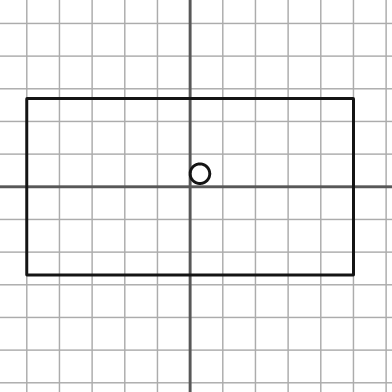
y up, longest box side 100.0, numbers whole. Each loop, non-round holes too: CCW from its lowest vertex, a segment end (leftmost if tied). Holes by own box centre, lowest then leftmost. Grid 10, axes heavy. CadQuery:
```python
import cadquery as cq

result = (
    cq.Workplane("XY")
    .moveTo(-50.0, -27.0)
    .lineTo(50.0, -27.0)
    .lineTo(50.0, 27.0)
    .lineTo(-50.0, 27.0)
    .close()
    .moveTo(3.0, 4.0)
    .circle(3.0)
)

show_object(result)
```